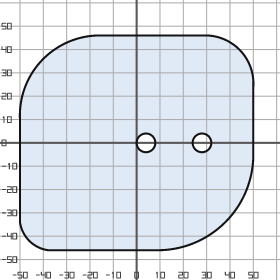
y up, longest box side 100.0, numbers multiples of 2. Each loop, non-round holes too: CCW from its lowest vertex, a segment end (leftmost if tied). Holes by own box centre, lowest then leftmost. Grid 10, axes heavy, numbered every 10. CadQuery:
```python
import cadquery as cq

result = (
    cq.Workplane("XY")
    .moveTo(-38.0, -46.0)
    .lineTo(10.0, -46.0)
    .threePointArc((38.0, -34.0), (50.0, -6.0))
    .lineTo(50.0, 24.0)
    .threePointArc((44.0, 40.0), (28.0, 46.0))
    .lineTo(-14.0, 46.0)
    .threePointArc((-40.0, 36.0), (-50.0, 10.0))
    .lineTo(-50.0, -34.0)
    .threePointArc((-46.0, -42.0), (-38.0, -46.0))
    .close()
    .moveTo(4.0, 0.0)
    .circle(4.0)
    .moveTo(28.0, 0.0)
    .circle(4.0)
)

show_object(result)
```